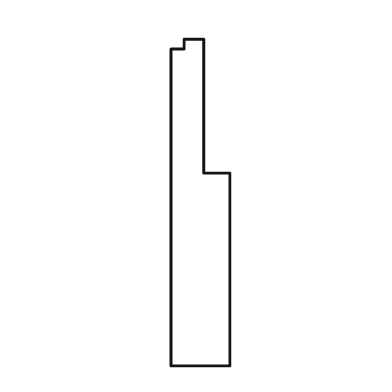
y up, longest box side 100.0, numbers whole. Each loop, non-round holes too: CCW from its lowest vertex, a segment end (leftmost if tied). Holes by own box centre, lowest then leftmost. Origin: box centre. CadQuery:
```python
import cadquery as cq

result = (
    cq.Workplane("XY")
    .moveTo(-9.0, -50.0)
    .lineTo(9.0, -50.0)
    .lineTo(9.0, 9.0)
    .lineTo(1.0, 9.0)
    .lineTo(1.0, 50.0)
    .lineTo(-5.0, 50.0)
    .lineTo(-5.0, 47.0)
    .lineTo(-9.0, 47.0)
    .close()
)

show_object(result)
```